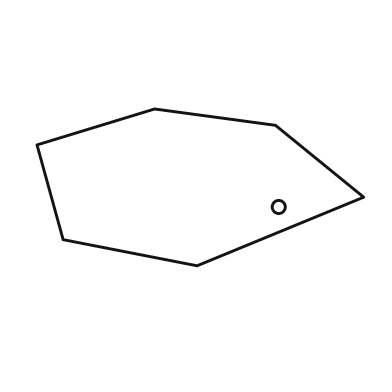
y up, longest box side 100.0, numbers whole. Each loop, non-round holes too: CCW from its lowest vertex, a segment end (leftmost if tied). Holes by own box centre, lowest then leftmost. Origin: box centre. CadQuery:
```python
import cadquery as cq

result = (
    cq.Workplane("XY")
    .moveTo(-1.0, -24.0)
    .lineTo(50.0, -3.0)
    .lineTo(23.0, 19.0)
    .lineTo(-14.0, 24.0)
    .lineTo(-50.0, 13.0)
    .lineTo(-42.0, -16.0)
    .close()
    .moveTo(24.0, -6.0)
    .circle(2.0)
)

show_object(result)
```